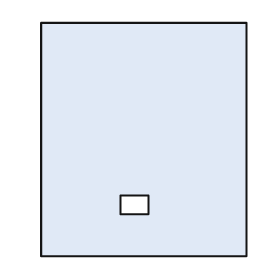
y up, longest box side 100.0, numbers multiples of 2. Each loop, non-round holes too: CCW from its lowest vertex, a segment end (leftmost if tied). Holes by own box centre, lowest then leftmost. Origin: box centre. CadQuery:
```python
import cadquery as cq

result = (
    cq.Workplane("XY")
    .moveTo(-44.0, -50.0)
    .lineTo(44.0, -50.0)
    .lineTo(44.0, 50.0)
    .lineTo(-44.0, 50.0)
    .close()
    .moveTo(-10.0, -32.0)
    .lineTo(2.0, -32.0)
    .lineTo(2.0, -24.0)
    .lineTo(-10.0, -24.0)
    .close()
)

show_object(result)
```